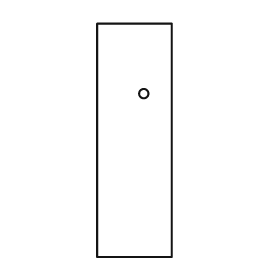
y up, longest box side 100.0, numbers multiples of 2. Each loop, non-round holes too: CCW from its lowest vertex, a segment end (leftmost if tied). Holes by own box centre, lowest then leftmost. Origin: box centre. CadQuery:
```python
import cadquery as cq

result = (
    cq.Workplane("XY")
    .moveTo(-16.0, -50.0)
    .lineTo(16.0, -50.0)
    .lineTo(16.0, 50.0)
    .lineTo(-16.0, 50.0)
    .close()
    .moveTo(4.0, 20.0)
    .circle(2.0)
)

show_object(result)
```